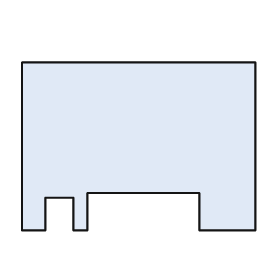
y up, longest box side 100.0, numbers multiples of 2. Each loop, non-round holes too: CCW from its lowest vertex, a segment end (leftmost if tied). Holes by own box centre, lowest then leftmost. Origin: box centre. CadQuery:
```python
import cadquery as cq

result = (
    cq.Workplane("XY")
    .moveTo(-50.0, -36.0)
    .lineTo(-40.0, -36.0)
    .lineTo(-40.0, -22.0)
    .lineTo(-28.0, -22.0)
    .lineTo(-28.0, -36.0)
    .lineTo(-22.0, -36.0)
    .lineTo(-22.0, -20.0)
    .lineTo(26.0, -20.0)
    .lineTo(26.0, -36.0)
    .lineTo(50.0, -36.0)
    .lineTo(50.0, 36.0)
    .lineTo(-50.0, 36.0)
    .close()
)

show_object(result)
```